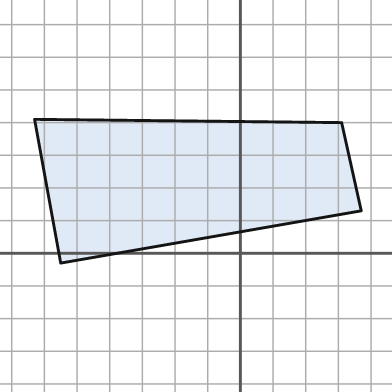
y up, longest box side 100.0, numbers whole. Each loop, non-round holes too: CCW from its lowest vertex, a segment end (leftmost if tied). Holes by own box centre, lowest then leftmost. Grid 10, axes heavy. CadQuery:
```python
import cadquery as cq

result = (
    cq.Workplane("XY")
    .moveTo(-55.0, -3.0)
    .lineTo(37.0, 13.0)
    .lineTo(31.0, 40.0)
    .lineTo(-63.0, 41.0)
    .close()
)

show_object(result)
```